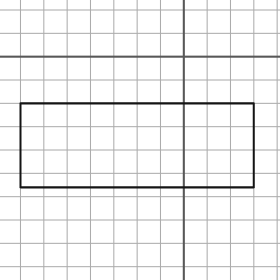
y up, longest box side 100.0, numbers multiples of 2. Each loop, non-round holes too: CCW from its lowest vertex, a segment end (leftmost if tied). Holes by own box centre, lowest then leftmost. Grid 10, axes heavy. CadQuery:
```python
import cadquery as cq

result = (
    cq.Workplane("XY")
    .moveTo(-70.0, -56.0)
    .lineTo(30.0, -56.0)
    .lineTo(30.0, -20.0)
    .lineTo(-70.0, -20.0)
    .close()
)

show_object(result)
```